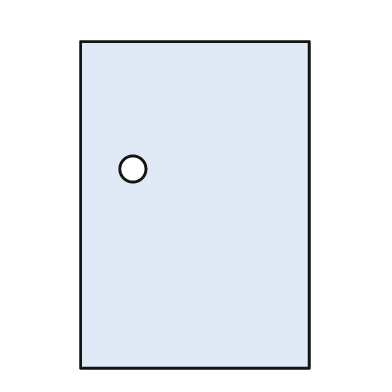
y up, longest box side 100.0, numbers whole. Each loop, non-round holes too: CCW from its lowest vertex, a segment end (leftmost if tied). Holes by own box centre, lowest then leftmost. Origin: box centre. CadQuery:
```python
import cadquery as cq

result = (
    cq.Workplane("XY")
    .moveTo(-35.0, -50.0)
    .lineTo(35.0, -50.0)
    .lineTo(35.0, 50.0)
    .lineTo(-35.0, 50.0)
    .close()
    .moveTo(-19.0, 11.0)
    .circle(4.0)
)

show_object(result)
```